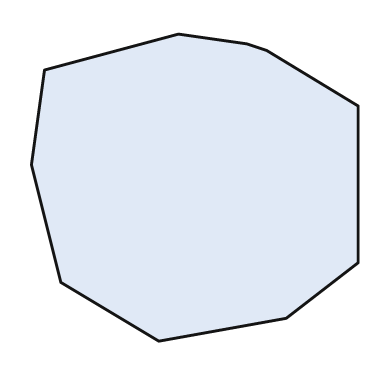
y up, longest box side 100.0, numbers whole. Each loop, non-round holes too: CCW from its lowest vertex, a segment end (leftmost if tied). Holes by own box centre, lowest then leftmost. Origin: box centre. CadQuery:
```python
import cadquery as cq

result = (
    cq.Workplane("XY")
    .moveTo(-11.0, -47.0)
    .lineTo(28.0, -40.0)
    .lineTo(50.0, -23.0)
    .lineTo(50.0, 25.0)
    .lineTo(22.0, 42.0)
    .lineTo(16.0, 44.0)
    .lineTo(-5.0, 47.0)
    .lineTo(-46.0, 36.0)
    .lineTo(-50.0, 7.0)
    .lineTo(-41.0, -29.0)
    .close()
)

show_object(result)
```